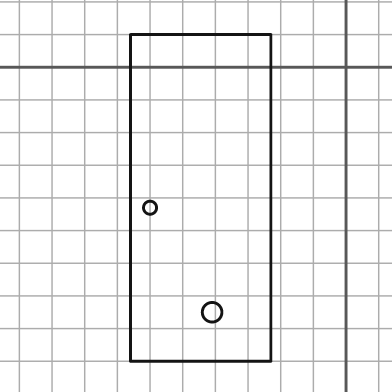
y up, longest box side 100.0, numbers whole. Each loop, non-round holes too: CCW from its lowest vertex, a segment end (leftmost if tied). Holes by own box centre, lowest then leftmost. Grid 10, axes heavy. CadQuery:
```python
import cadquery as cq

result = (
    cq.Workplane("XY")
    .moveTo(-66.0, -90.0)
    .lineTo(-23.0, -90.0)
    .lineTo(-23.0, 10.0)
    .lineTo(-66.0, 10.0)
    .close()
    .moveTo(-41.0, -75.0)
    .circle(3.0)
    .moveTo(-60.0, -43.0)
    .circle(2.0)
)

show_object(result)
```